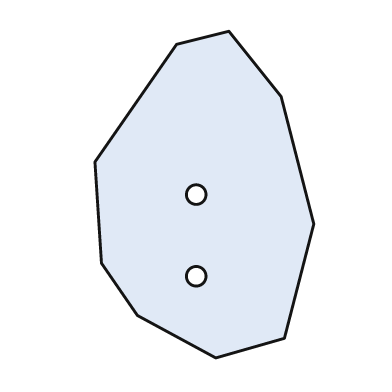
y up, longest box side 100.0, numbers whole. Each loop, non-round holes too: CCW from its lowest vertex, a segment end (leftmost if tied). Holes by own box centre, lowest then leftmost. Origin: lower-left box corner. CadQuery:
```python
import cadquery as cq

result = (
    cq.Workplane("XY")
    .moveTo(37.0, 0.0)
    .lineTo(58.0, 6.0)
    .lineTo(67.0, 41.0)
    .lineTo(57.0, 80.0)
    .lineTo(41.0, 100.0)
    .lineTo(25.0, 96.0)
    .lineTo(0.0, 60.0)
    .lineTo(2.0, 29.0)
    .lineTo(13.0, 13.0)
    .close()
    .moveTo(31.0, 25.0)
    .circle(3.0)
    .moveTo(31.0, 50.0)
    .circle(3.0)
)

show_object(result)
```